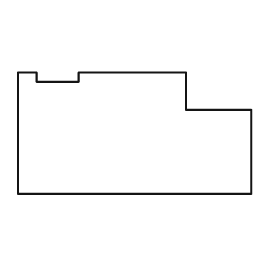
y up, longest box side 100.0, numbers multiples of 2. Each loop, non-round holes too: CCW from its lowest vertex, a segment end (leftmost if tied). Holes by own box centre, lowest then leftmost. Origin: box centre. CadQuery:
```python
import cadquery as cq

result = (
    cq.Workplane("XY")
    .moveTo(-50.0, -26.0)
    .lineTo(50.0, -26.0)
    .lineTo(50.0, 10.0)
    .lineTo(22.0, 10.0)
    .lineTo(22.0, 26.0)
    .lineTo(-24.0, 26.0)
    .lineTo(-24.0, 22.0)
    .lineTo(-42.0, 22.0)
    .lineTo(-42.0, 26.0)
    .lineTo(-50.0, 26.0)
    .close()
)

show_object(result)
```